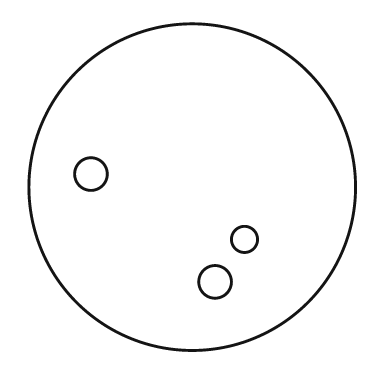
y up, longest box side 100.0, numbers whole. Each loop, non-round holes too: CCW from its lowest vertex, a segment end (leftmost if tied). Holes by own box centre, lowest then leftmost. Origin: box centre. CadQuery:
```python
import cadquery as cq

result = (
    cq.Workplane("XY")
    .moveTo(0.0, 0.0)
    .circle(50.0)
    .moveTo(7.0, -29.0)
    .circle(5.0)
    .moveTo(16.0, -16.0)
    .circle(4.0)
    .moveTo(-31.0, 4.0)
    .circle(5.0)
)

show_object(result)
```